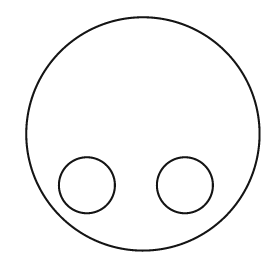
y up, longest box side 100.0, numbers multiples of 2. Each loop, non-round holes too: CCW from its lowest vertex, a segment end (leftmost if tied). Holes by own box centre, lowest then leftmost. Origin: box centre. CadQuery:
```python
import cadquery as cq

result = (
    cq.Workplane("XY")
    .moveTo(0.0, 0.0)
    .circle(50.0)
    .moveTo(-24.0, -22.0)
    .circle(12.0)
    .moveTo(18.0, -22.0)
    .circle(12.0)
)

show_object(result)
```